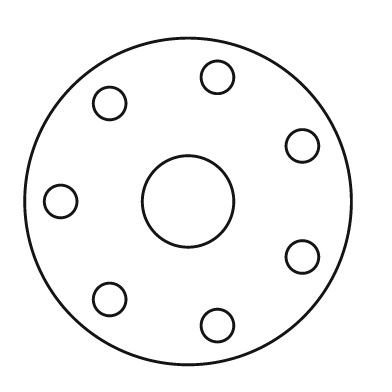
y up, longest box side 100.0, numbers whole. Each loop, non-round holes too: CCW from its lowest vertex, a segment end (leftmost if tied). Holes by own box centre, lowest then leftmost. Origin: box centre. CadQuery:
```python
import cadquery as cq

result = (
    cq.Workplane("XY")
    .moveTo(0.0, 0.0)
    .circle(50.0)
    .moveTo(9.0, -38.0)
    .circle(5.0)
    .moveTo(-24.0, -30.0)
    .circle(5.0)
    .moveTo(35.0, -17.0)
    .circle(5.0)
    .moveTo(-39.0, 0.0)
    .circle(5.0)
    .moveTo(0.0, 0.0)
    .circle(14.0)
    .moveTo(35.0, 17.0)
    .circle(5.0)
    .moveTo(-24.0, 30.0)
    .circle(5.0)
    .moveTo(9.0, 38.0)
    .circle(5.0)
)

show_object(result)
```